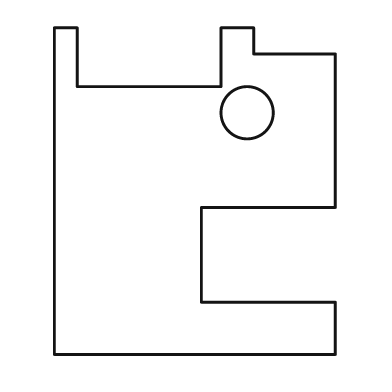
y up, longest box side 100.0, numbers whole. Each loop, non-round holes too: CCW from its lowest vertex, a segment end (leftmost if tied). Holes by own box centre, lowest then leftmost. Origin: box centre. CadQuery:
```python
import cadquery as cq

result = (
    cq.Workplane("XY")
    .moveTo(-43.0, -50.0)
    .lineTo(43.0, -50.0)
    .lineTo(43.0, -34.0)
    .lineTo(2.0, -34.0)
    .lineTo(2.0, -5.0)
    .lineTo(43.0, -5.0)
    .lineTo(43.0, 42.0)
    .lineTo(18.0, 42.0)
    .lineTo(18.0, 50.0)
    .lineTo(8.0, 50.0)
    .lineTo(8.0, 32.0)
    .lineTo(-36.0, 32.0)
    .lineTo(-36.0, 50.0)
    .lineTo(-43.0, 50.0)
    .close()
    .moveTo(16.0, 24.0)
    .circle(8.0)
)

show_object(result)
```